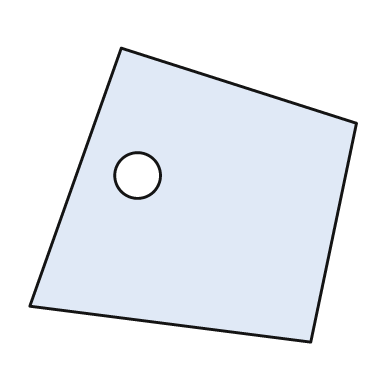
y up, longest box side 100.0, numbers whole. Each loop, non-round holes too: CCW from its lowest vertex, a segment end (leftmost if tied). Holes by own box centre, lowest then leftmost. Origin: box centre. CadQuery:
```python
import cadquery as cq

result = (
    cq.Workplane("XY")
    .moveTo(36.0, -45.0)
    .lineTo(50.0, 22.0)
    .lineTo(-22.0, 45.0)
    .lineTo(-50.0, -34.0)
    .close()
    .moveTo(-17.0, 6.0)
    .circle(7.0)
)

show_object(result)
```